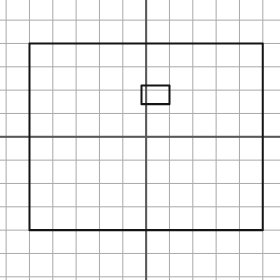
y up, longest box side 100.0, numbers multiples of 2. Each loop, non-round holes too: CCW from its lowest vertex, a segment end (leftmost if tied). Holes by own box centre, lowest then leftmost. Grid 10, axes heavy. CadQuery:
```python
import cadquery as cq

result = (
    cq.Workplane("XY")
    .moveTo(-50.0, -40.0)
    .lineTo(50.0, -40.0)
    .lineTo(50.0, 40.0)
    .lineTo(-50.0, 40.0)
    .close()
    .moveTo(-2.0, 14.0)
    .lineTo(10.0, 14.0)
    .lineTo(10.0, 22.0)
    .lineTo(-2.0, 22.0)
    .close()
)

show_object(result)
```